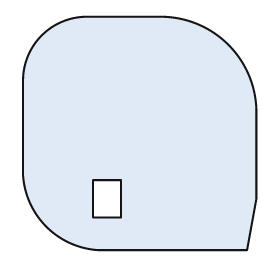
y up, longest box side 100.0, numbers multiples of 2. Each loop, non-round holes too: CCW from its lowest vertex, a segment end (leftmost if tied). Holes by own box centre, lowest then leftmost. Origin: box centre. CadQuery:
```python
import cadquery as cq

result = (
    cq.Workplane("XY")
    .moveTo(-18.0, -50.0)
    .lineTo(46.0, -50.0)
    .lineTo(50.0, -28.0)
    .lineTo(50.0, 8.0)
    .threePointArc((38.0, 38.0), (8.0, 50.0))
    .lineTo(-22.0, 50.0)
    .threePointArc((-42.0, 42.0), (-50.0, 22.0))
    .lineTo(-50.0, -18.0)
    .threePointArc((-40.0, -40.0), (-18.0, -50.0))
    .close()
    .moveTo(-20.0, -36.0)
    .lineTo(-8.0, -36.0)
    .lineTo(-8.0, -20.0)
    .lineTo(-20.0, -20.0)
    .close()
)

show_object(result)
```